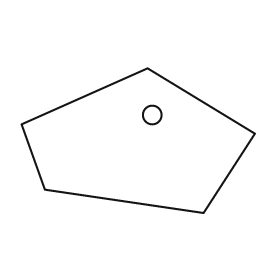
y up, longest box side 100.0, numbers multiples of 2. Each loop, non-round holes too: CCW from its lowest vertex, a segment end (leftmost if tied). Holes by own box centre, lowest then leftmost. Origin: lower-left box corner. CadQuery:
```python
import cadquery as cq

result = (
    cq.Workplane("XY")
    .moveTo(78.0, 0.0)
    .lineTo(100.0, 34.0)
    .lineTo(54.0, 62.0)
    .lineTo(0.0, 38.0)
    .lineTo(10.0, 10.0)
    .close()
    .moveTo(56.0, 42.0)
    .circle(4.0)
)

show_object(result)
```